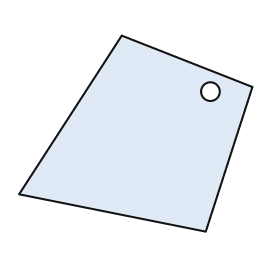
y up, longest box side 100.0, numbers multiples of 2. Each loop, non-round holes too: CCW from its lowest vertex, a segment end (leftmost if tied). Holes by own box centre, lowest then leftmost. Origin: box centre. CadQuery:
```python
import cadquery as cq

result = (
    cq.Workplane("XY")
    .moveTo(30.0, -42.0)
    .lineTo(50.0, 20.0)
    .lineTo(-6.0, 42.0)
    .lineTo(-50.0, -26.0)
    .close()
    .moveTo(32.0, 18.0)
    .circle(4.0)
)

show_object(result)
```